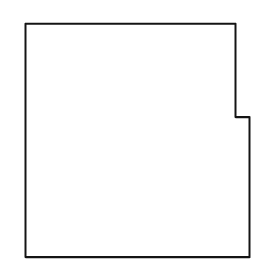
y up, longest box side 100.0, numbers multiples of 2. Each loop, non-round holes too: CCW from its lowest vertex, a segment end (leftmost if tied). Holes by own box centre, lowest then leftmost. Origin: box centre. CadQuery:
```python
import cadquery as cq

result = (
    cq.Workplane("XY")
    .moveTo(-48.0, -50.0)
    .lineTo(48.0, -50.0)
    .lineTo(48.0, 10.0)
    .lineTo(42.0, 10.0)
    .lineTo(42.0, 50.0)
    .lineTo(-48.0, 50.0)
    .close()
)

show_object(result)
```